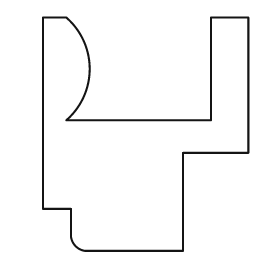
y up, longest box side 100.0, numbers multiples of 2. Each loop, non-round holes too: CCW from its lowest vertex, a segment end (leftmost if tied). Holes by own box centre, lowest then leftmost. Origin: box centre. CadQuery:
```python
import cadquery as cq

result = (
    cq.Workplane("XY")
    .moveTo(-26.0, -50.0)
    .lineTo(16.0, -50.0)
    .lineTo(16.0, -8.0)
    .lineTo(44.0, -8.0)
    .lineTo(44.0, 50.0)
    .lineTo(28.0, 50.0)
    .lineTo(28.0, 6.0)
    .lineTo(-34.0, 6.0)
    .threePointArc((-24.0, 28.0), (-34.0, 50.0))
    .lineTo(-44.0, 50.0)
    .lineTo(-44.0, -32.0)
    .lineTo(-32.0, -32.0)
    .lineTo(-32.0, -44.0)
    .threePointArc((-30.0, -48.0), (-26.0, -50.0))
    .close()
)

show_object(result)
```